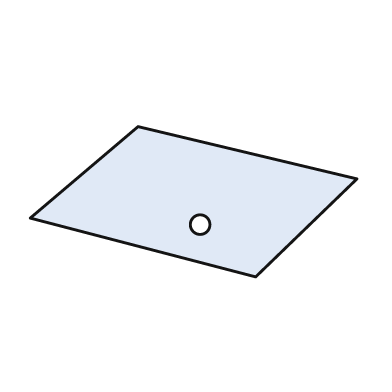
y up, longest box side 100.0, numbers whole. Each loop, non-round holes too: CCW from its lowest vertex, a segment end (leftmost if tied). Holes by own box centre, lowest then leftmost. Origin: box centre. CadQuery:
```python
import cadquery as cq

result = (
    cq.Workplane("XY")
    .moveTo(19.0, -23.0)
    .lineTo(50.0, 7.0)
    .lineTo(-17.0, 23.0)
    .lineTo(-50.0, -5.0)
    .close()
    .moveTo(2.0, -7.0)
    .circle(3.0)
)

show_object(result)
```